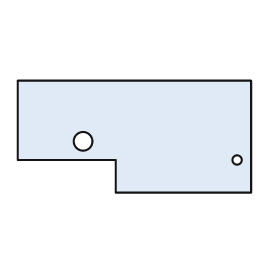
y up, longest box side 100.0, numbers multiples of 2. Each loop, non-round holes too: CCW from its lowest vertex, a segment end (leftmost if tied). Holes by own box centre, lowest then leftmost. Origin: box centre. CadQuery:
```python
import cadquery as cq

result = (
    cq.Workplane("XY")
    .moveTo(-8.0, -24.0)
    .lineTo(50.0, -24.0)
    .lineTo(50.0, 24.0)
    .lineTo(-50.0, 24.0)
    .lineTo(-50.0, -10.0)
    .lineTo(-8.0, -10.0)
    .close()
    .moveTo(44.0, -10.0)
    .circle(2.0)
    .moveTo(-22.0, -2.0)
    .circle(4.0)
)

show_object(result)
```